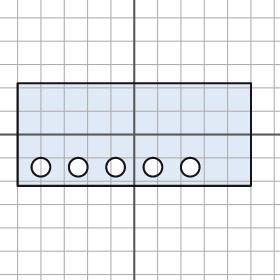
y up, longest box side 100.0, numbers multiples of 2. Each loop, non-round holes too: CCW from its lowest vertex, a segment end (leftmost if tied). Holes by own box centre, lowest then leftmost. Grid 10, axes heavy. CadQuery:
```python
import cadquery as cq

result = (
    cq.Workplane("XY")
    .moveTo(-50.0, -22.0)
    .lineTo(50.0, -22.0)
    .lineTo(50.0, 22.0)
    .lineTo(-50.0, 22.0)
    .close()
    .moveTo(-40.0, -14.0)
    .circle(4.0)
    .moveTo(-24.0, -14.0)
    .circle(4.0)
    .moveTo(-8.0, -14.0)
    .circle(4.0)
    .moveTo(8.0, -14.0)
    .circle(4.0)
    .moveTo(24.0, -14.0)
    .circle(4.0)
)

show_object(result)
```